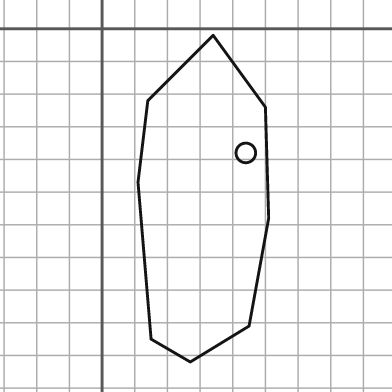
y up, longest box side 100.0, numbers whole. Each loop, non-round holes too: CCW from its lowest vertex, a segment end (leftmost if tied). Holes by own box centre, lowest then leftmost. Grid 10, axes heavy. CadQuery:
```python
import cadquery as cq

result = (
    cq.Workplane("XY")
    .moveTo(27.0, -102.0)
    .lineTo(45.0, -91.0)
    .lineTo(51.0, -58.0)
    .lineTo(50.0, -24.0)
    .lineTo(34.0, -2.0)
    .lineTo(14.0, -22.0)
    .lineTo(11.0, -47.0)
    .lineTo(15.0, -95.0)
    .close()
    .moveTo(44.0, -38.0)
    .circle(3.0)
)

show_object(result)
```